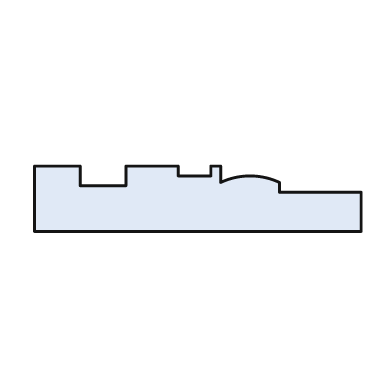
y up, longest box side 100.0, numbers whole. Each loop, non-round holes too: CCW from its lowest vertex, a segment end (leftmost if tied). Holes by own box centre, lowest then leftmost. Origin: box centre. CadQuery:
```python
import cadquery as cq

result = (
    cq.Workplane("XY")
    .moveTo(-50.0, -10.0)
    .lineTo(50.0, -10.0)
    .lineTo(50.0, 2.0)
    .lineTo(25.0, 2.0)
    .lineTo(25.0, 5.0)
    .threePointArc((16.0, 7.0), (7.0, 5.0))
    .lineTo(7.0, 10.0)
    .lineTo(4.0, 10.0)
    .lineTo(4.0, 7.0)
    .lineTo(-6.0, 7.0)
    .lineTo(-6.0, 10.0)
    .lineTo(-22.0, 10.0)
    .lineTo(-22.0, 4.0)
    .lineTo(-36.0, 4.0)
    .lineTo(-36.0, 10.0)
    .lineTo(-50.0, 10.0)
    .close()
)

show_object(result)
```